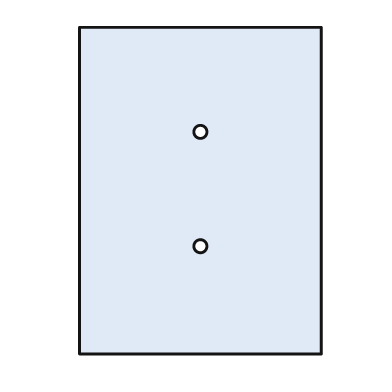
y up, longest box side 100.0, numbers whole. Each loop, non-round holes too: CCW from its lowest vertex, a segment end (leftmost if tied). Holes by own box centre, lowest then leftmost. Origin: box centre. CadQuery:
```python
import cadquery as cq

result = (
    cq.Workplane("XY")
    .moveTo(-37.0, -50.0)
    .lineTo(37.0, -50.0)
    .lineTo(37.0, 50.0)
    .lineTo(-37.0, 50.0)
    .close()
    .moveTo(0.0, -17.0)
    .circle(2.0)
    .moveTo(0.0, 18.0)
    .circle(2.0)
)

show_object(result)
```